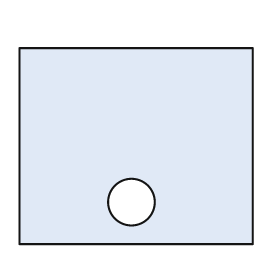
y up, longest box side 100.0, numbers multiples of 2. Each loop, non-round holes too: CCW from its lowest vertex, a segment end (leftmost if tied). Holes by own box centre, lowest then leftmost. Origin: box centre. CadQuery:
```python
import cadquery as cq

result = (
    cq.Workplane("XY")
    .moveTo(-50.0, -42.0)
    .lineTo(50.0, -42.0)
    .lineTo(50.0, 42.0)
    .lineTo(-50.0, 42.0)
    .close()
    .moveTo(-2.0, -24.0)
    .circle(10.0)
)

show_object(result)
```